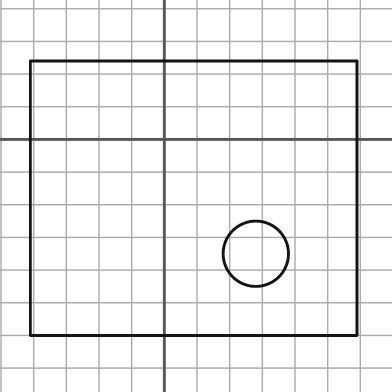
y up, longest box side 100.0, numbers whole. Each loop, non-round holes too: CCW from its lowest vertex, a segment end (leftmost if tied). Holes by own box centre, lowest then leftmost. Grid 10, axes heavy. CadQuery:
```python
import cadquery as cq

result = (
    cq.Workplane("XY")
    .moveTo(-41.0, -60.0)
    .lineTo(59.0, -60.0)
    .lineTo(59.0, 24.0)
    .lineTo(-41.0, 24.0)
    .close()
    .moveTo(28.0, -35.0)
    .circle(10.0)
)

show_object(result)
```